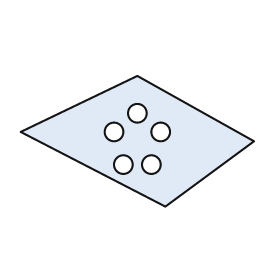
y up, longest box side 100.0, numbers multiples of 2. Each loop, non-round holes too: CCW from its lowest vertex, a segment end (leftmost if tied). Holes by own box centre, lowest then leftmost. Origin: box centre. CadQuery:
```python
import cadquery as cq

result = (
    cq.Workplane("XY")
    .moveTo(12.0, -28.0)
    .lineTo(50.0, 0.0)
    .lineTo(0.0, 28.0)
    .lineTo(-50.0, 4.0)
    .close()
    .moveTo(-6.0, -10.0)
    .circle(4.0)
    .moveTo(6.0, -10.0)
    .circle(4.0)
    .moveTo(-10.0, 4.0)
    .circle(4.0)
    .moveTo(10.0, 4.0)
    .circle(4.0)
    .moveTo(0.0, 12.0)
    .circle(4.0)
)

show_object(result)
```